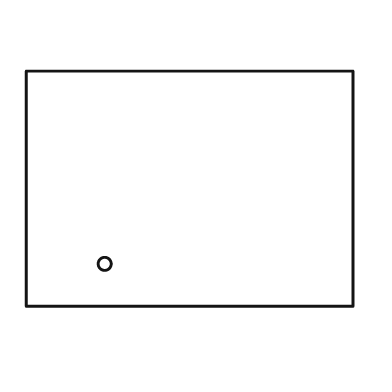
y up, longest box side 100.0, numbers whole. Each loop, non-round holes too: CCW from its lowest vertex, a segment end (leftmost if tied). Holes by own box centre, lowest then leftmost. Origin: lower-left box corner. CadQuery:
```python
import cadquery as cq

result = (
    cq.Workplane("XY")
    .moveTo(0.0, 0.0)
    .lineTo(100.0, 0.0)
    .lineTo(100.0, 72.0)
    .lineTo(0.0, 72.0)
    .close()
    .moveTo(24.0, 13.0)
    .circle(2.0)
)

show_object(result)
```